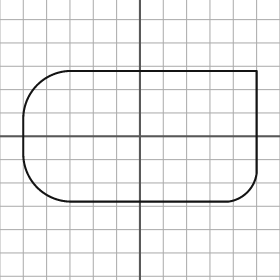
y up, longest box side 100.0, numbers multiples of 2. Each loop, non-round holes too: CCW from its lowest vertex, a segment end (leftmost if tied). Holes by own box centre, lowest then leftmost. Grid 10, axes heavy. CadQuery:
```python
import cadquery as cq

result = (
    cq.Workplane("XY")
    .moveTo(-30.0, -28.0)
    .lineTo(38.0, -28.0)
    .threePointArc((46.0, -24.0), (50.0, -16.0))
    .lineTo(50.0, 28.0)
    .lineTo(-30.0, 28.0)
    .threePointArc((-44.0, 22.0), (-50.0, 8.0))
    .lineTo(-50.0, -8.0)
    .threePointArc((-44.0, -22.0), (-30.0, -28.0))
    .close()
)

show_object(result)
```